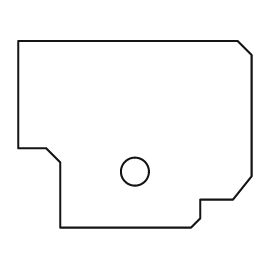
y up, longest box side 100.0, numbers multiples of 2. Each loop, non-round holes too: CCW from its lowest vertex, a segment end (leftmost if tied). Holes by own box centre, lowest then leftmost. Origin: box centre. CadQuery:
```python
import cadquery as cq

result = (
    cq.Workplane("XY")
    .moveTo(-32.0, -40.0)
    .lineTo(24.0, -40.0)
    .lineTo(28.0, -36.0)
    .lineTo(28.0, -28.0)
    .lineTo(42.0, -28.0)
    .lineTo(50.0, -18.0)
    .lineTo(50.0, 34.0)
    .lineTo(44.0, 40.0)
    .lineTo(-50.0, 40.0)
    .lineTo(-50.0, -6.0)
    .lineTo(-38.0, -6.0)
    .lineTo(-32.0, -12.0)
    .close()
    .moveTo(0.0, -16.0)
    .circle(6.0)
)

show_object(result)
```